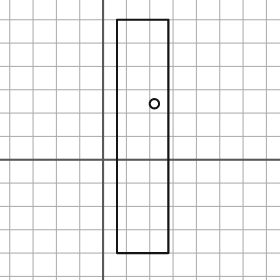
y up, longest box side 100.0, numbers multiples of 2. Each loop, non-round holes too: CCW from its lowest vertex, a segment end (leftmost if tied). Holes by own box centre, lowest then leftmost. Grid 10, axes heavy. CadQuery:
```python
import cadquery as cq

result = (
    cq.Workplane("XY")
    .moveTo(6.0, -40.0)
    .lineTo(28.0, -40.0)
    .lineTo(28.0, 60.0)
    .lineTo(6.0, 60.0)
    .close()
    .moveTo(22.0, 24.0)
    .circle(2.0)
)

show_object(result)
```